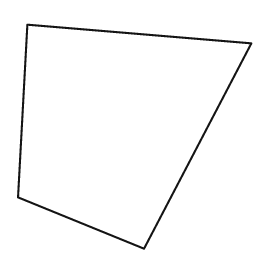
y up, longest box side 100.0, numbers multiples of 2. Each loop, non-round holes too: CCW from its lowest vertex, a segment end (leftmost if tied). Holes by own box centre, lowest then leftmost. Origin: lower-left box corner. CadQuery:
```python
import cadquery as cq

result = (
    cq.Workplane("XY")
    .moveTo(54.0, 0.0)
    .lineTo(100.0, 88.0)
    .lineTo(4.0, 96.0)
    .lineTo(0.0, 22.0)
    .close()
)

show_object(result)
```